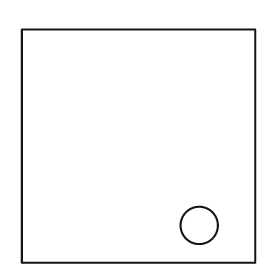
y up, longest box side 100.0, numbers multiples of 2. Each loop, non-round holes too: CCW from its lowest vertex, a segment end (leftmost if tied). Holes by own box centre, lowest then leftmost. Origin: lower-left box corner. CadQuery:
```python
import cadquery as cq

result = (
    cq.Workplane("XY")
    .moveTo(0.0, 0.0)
    .lineTo(100.0, 0.0)
    .lineTo(100.0, 100.0)
    .lineTo(0.0, 100.0)
    .close()
    .moveTo(76.0, 16.0)
    .circle(8.0)
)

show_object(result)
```